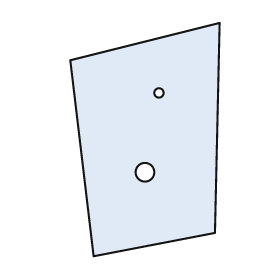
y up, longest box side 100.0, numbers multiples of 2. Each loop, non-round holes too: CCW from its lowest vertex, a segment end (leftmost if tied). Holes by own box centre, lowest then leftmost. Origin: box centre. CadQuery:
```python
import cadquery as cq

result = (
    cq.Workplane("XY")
    .moveTo(-22.0, -50.0)
    .lineTo(30.0, -40.0)
    .lineTo(32.0, 50.0)
    .lineTo(-32.0, 34.0)
    .close()
    .moveTo(0.0, -14.0)
    .circle(4.0)
    .moveTo(6.0, 20.0)
    .circle(2.0)
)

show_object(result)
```